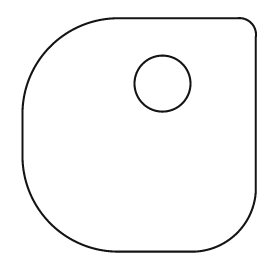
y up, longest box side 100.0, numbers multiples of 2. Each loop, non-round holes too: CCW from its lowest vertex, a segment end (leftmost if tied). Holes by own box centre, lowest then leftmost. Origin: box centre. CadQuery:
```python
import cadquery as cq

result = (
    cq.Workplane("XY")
    .moveTo(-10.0, -50.0)
    .lineTo(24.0, -50.0)
    .threePointArc((42.0, -42.0), (50.0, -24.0))
    .lineTo(50.0, 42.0)
    .threePointArc((48.0, 48.0), (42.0, 50.0))
    .lineTo(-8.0, 50.0)
    .threePointArc((-38.0, 38.0), (-50.0, 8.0))
    .lineTo(-50.0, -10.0)
    .threePointArc((-38.0, -38.0), (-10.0, -50.0))
    .close()
    .moveTo(10.0, 22.0)
    .circle(12.0)
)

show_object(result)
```